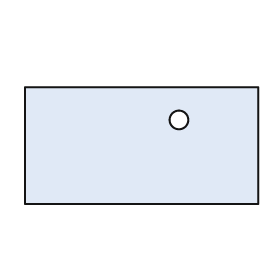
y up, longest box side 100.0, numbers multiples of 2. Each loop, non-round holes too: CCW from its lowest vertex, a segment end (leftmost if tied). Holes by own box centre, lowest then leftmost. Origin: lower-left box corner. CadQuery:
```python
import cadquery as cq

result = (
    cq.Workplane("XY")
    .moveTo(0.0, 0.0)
    .lineTo(100.0, 0.0)
    .lineTo(100.0, 50.0)
    .lineTo(0.0, 50.0)
    .close()
    .moveTo(66.0, 36.0)
    .circle(4.0)
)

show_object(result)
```